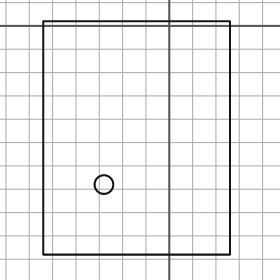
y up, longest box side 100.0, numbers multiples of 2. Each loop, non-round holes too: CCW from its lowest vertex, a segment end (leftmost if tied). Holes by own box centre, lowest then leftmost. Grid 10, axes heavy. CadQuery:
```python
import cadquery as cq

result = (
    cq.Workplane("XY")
    .moveTo(-54.0, -98.0)
    .lineTo(26.0, -98.0)
    .lineTo(26.0, 2.0)
    .lineTo(-54.0, 2.0)
    .close()
    .moveTo(-28.0, -68.0)
    .circle(4.0)
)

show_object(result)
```